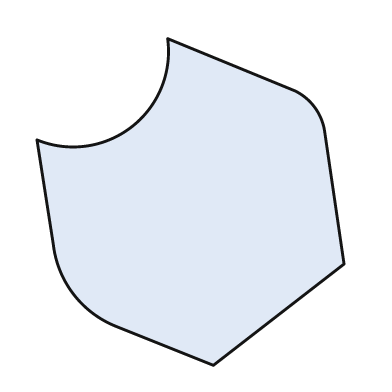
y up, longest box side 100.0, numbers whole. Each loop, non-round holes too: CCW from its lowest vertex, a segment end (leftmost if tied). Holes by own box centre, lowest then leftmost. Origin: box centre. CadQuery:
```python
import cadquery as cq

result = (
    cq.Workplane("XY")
    .moveTo(7.0, -50.0)
    .lineTo(47.0, -19.0)
    .lineTo(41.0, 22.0)
    .threePointArc((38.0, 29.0), (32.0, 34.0))
    .lineTo(-7.0, 50.0)
    .threePointArc((-18.0, 23.0), (-47.0, 19.0))
    .lineTo(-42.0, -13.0)
    .threePointArc((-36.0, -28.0), (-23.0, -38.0))
    .close()
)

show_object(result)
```